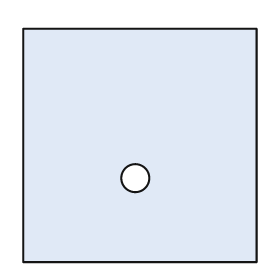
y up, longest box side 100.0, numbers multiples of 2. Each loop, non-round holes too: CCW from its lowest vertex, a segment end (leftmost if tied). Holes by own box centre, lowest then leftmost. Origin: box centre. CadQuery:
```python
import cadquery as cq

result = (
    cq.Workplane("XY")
    .moveTo(-50.0, -50.0)
    .lineTo(50.0, -50.0)
    .lineTo(50.0, 50.0)
    .lineTo(-50.0, 50.0)
    .close()
    .moveTo(-2.0, -14.0)
    .circle(6.0)
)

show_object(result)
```